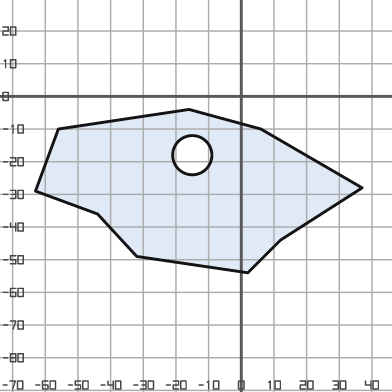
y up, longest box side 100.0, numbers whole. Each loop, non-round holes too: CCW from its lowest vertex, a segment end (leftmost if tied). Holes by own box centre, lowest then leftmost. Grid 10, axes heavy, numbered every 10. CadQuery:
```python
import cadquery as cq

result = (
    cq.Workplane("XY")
    .moveTo(2.0, -54.0)
    .lineTo(12.0, -44.0)
    .lineTo(37.0, -28.0)
    .lineTo(6.0, -10.0)
    .lineTo(-16.0, -4.0)
    .lineTo(-56.0, -10.0)
    .lineTo(-63.0, -29.0)
    .lineTo(-44.0, -36.0)
    .lineTo(-32.0, -49.0)
    .close()
    .moveTo(-15.0, -18.0)
    .circle(6.0)
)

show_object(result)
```